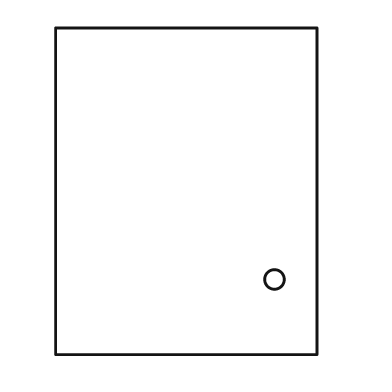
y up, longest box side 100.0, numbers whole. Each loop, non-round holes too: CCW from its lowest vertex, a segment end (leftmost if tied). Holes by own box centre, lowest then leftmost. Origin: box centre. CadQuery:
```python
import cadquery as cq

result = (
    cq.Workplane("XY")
    .moveTo(-40.0, -50.0)
    .lineTo(40.0, -50.0)
    .lineTo(40.0, 50.0)
    .lineTo(-40.0, 50.0)
    .close()
    .moveTo(27.0, -27.0)
    .circle(3.0)
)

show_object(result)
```